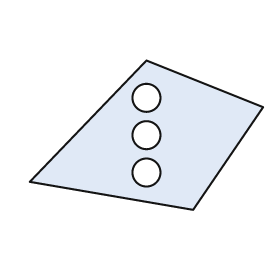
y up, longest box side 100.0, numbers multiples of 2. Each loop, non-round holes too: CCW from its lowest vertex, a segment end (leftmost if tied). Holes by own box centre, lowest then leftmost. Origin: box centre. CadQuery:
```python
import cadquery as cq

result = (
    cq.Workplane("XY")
    .moveTo(20.0, -32.0)
    .lineTo(50.0, 12.0)
    .lineTo(0.0, 32.0)
    .lineTo(-50.0, -20.0)
    .close()
    .moveTo(0.0, -16.0)
    .circle(6.0)
    .moveTo(0.0, 0.0)
    .circle(6.0)
    .moveTo(0.0, 16.0)
    .circle(6.0)
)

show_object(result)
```